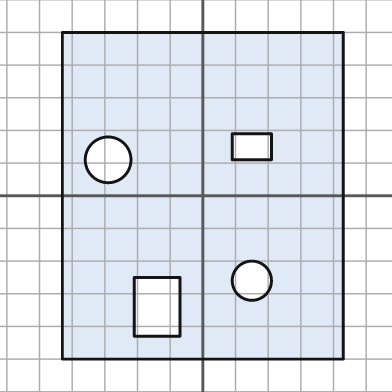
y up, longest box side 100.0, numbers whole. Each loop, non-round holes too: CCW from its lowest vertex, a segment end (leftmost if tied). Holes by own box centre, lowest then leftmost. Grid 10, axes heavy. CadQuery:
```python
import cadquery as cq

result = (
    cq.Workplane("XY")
    .moveTo(-43.0, -50.0)
    .lineTo(43.0, -50.0)
    .lineTo(43.0, 50.0)
    .lineTo(-43.0, 50.0)
    .close()
    .moveTo(-21.0, -43.0)
    .lineTo(-7.0, -43.0)
    .lineTo(-7.0, -25.0)
    .lineTo(-21.0, -25.0)
    .close()
    .moveTo(15.0, -26.0)
    .circle(6.0)
    .moveTo(-29.0, 11.0)
    .circle(7.0)
    .moveTo(9.0, 11.0)
    .lineTo(21.0, 11.0)
    .lineTo(21.0, 19.0)
    .lineTo(9.0, 19.0)
    .close()
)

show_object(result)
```